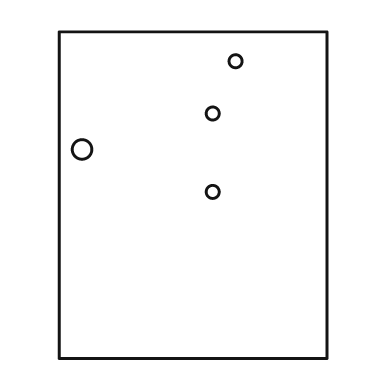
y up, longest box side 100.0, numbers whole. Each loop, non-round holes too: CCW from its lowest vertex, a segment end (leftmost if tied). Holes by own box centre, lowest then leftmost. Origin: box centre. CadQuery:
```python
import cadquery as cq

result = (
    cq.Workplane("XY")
    .moveTo(-41.0, -50.0)
    .lineTo(41.0, -50.0)
    .lineTo(41.0, 50.0)
    .lineTo(-41.0, 50.0)
    .close()
    .moveTo(6.0, 1.0)
    .circle(2.0)
    .moveTo(-34.0, 14.0)
    .circle(3.0)
    .moveTo(6.0, 25.0)
    .circle(2.0)
    .moveTo(13.0, 41.0)
    .circle(2.0)
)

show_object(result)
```